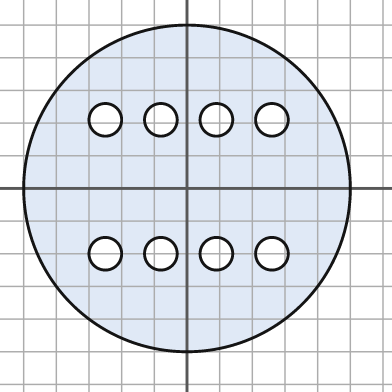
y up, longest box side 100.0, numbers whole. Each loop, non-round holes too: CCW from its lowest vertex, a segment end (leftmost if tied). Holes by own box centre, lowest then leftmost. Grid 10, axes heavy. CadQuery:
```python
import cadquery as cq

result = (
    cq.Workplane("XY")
    .moveTo(0.0, 0.0)
    .circle(50.0)
    .moveTo(-25.0, -20.0)
    .circle(5.0)
    .moveTo(-8.0, -20.0)
    .circle(5.0)
    .moveTo(9.0, -20.0)
    .circle(5.0)
    .moveTo(26.0, -20.0)
    .circle(5.0)
    .moveTo(-25.0, 21.0)
    .circle(5.0)
    .moveTo(-8.0, 21.0)
    .circle(5.0)
    .moveTo(9.0, 21.0)
    .circle(5.0)
    .moveTo(26.0, 21.0)
    .circle(5.0)
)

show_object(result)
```